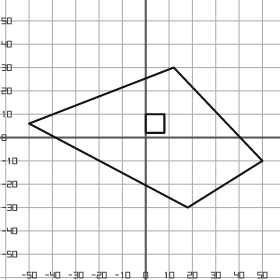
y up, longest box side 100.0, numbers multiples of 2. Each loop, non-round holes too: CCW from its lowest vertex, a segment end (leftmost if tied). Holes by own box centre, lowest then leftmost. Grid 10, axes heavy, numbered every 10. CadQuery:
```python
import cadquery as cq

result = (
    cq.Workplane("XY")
    .moveTo(18.0, -30.0)
    .lineTo(50.0, -10.0)
    .lineTo(12.0, 30.0)
    .lineTo(-50.0, 6.0)
    .close()
    .moveTo(0.0, 2.0)
    .lineTo(8.0, 2.0)
    .lineTo(8.0, 10.0)
    .lineTo(0.0, 10.0)
    .close()
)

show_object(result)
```